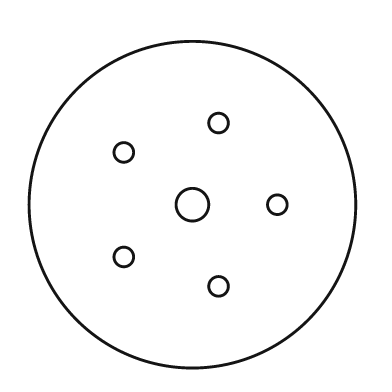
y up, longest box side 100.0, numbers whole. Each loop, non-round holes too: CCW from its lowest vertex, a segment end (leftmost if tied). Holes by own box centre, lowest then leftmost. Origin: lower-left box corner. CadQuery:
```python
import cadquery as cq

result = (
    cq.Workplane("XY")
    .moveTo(50.0, 50.0)
    .circle(50.0)
    .moveTo(58.0, 25.0)
    .circle(3.0)
    .moveTo(29.0, 34.0)
    .circle(3.0)
    .moveTo(50.0, 50.0)
    .circle(5.0)
    .moveTo(76.0, 50.0)
    .circle(3.0)
    .moveTo(29.0, 66.0)
    .circle(3.0)
    .moveTo(58.0, 75.0)
    .circle(3.0)
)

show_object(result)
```